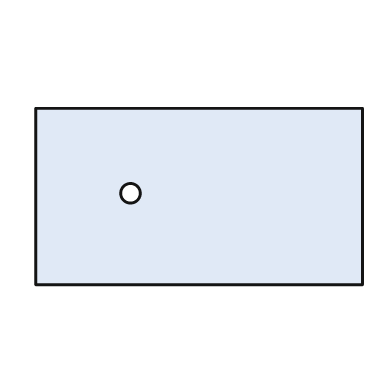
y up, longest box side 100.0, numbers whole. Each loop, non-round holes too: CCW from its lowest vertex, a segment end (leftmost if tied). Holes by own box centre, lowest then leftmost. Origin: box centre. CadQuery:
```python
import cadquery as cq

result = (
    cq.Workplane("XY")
    .moveTo(-50.0, -27.0)
    .lineTo(50.0, -27.0)
    .lineTo(50.0, 27.0)
    .lineTo(-50.0, 27.0)
    .close()
    .moveTo(-21.0, 1.0)
    .circle(3.0)
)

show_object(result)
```